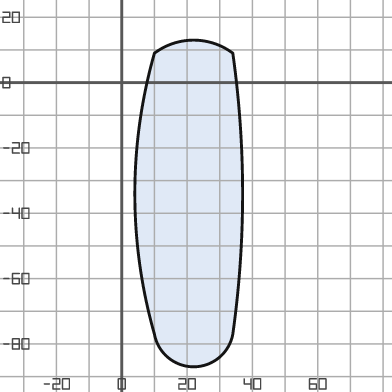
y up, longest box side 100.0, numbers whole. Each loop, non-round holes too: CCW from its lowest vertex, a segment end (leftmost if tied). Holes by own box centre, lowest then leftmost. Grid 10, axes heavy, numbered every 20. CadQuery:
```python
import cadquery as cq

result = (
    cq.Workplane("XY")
    .moveTo(10.0, -77.0)
    .threePointArc((22.0, -87.0), (34.0, -77.0))
    .threePointArc((37.0, -34.0), (34.0, 9.0))
    .threePointArc((22.0, 13.0), (10.0, 9.0))
    .threePointArc((4.0, -34.0), (10.0, -77.0))
    .close()
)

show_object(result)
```